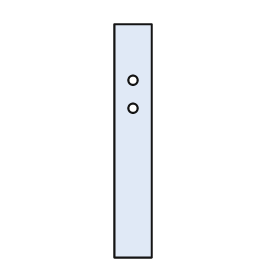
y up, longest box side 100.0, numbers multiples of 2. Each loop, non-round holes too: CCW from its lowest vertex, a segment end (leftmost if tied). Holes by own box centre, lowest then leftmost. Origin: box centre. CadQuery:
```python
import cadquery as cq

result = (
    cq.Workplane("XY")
    .moveTo(-8.0, -50.0)
    .lineTo(8.0, -50.0)
    .lineTo(8.0, 50.0)
    .lineTo(-8.0, 50.0)
    .close()
    .moveTo(0.0, 14.0)
    .circle(2.0)
    .moveTo(0.0, 26.0)
    .circle(2.0)
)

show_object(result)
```